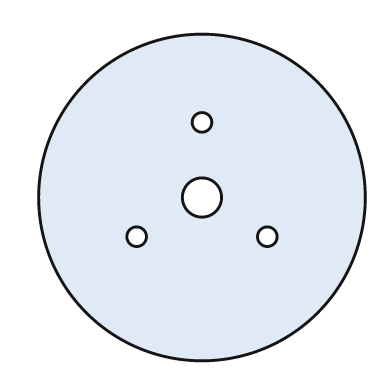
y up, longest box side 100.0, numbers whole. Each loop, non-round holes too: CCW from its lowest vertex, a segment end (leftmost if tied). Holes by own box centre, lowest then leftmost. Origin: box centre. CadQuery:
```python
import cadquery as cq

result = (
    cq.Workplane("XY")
    .moveTo(0.0, 0.0)
    .circle(50.0)
    .moveTo(-20.0, -12.0)
    .circle(3.0)
    .moveTo(20.0, -12.0)
    .circle(3.0)
    .moveTo(0.0, 0.0)
    .circle(6.0)
    .moveTo(0.0, 23.0)
    .circle(3.0)
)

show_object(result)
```